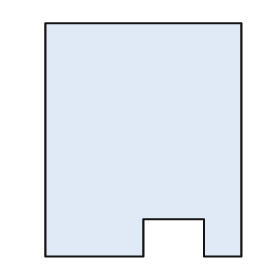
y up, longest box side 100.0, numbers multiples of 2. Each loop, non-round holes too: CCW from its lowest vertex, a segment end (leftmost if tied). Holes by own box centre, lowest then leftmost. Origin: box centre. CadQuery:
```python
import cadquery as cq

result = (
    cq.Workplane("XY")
    .moveTo(-42.0, -50.0)
    .lineTo(0.0, -50.0)
    .lineTo(0.0, -34.0)
    .lineTo(26.0, -34.0)
    .lineTo(26.0, -50.0)
    .lineTo(42.0, -50.0)
    .lineTo(42.0, 50.0)
    .lineTo(-42.0, 50.0)
    .close()
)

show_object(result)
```